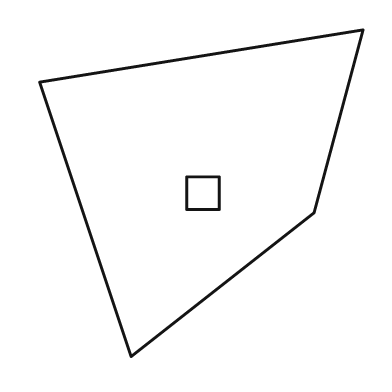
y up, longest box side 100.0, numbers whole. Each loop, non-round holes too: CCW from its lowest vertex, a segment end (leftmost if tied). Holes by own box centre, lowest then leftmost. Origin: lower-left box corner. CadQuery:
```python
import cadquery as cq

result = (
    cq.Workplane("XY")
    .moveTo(28.0, 0.0)
    .lineTo(84.0, 44.0)
    .lineTo(99.0, 100.0)
    .lineTo(0.0, 84.0)
    .close()
    .moveTo(45.0, 45.0)
    .lineTo(55.0, 45.0)
    .lineTo(55.0, 55.0)
    .lineTo(45.0, 55.0)
    .close()
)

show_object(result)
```